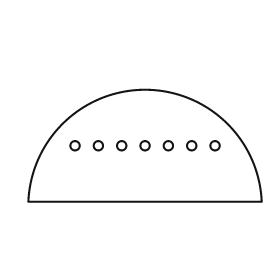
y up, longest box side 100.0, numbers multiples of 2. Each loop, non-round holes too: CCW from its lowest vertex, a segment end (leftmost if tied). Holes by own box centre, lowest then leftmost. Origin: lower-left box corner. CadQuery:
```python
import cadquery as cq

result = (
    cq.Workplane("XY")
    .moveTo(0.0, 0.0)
    .lineTo(100.0, 0.0)
    .threePointArc((50.0, 48.0), (0.0, 0.0))
    .close()
    .moveTo(20.0, 24.0)
    .circle(2.0)
    .moveTo(30.0, 24.0)
    .circle(2.0)
    .moveTo(40.0, 24.0)
    .circle(2.0)
    .moveTo(50.0, 24.0)
    .circle(2.0)
    .moveTo(60.0, 24.0)
    .circle(2.0)
    .moveTo(70.0, 24.0)
    .circle(2.0)
    .moveTo(80.0, 24.0)
    .circle(2.0)
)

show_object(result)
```